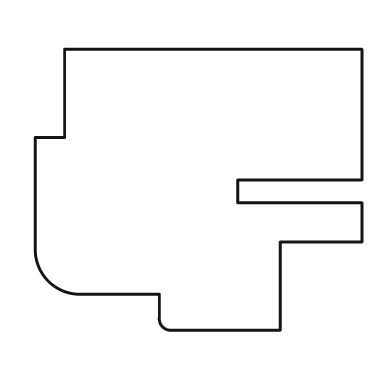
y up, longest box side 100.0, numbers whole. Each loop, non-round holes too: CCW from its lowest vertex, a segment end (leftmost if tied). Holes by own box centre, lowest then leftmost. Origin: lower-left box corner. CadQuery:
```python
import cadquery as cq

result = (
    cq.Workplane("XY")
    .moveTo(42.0, 0.0)
    .lineTo(75.0, 0.0)
    .lineTo(75.0, 27.0)
    .lineTo(100.0, 27.0)
    .lineTo(100.0, 39.0)
    .lineTo(62.0, 39.0)
    .lineTo(62.0, 46.0)
    .lineTo(100.0, 46.0)
    .lineTo(100.0, 86.0)
    .lineTo(9.0, 86.0)
    .lineTo(9.0, 59.0)
    .lineTo(0.0, 59.0)
    .lineTo(0.0, 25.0)
    .threePointArc((4.0, 15.0), (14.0, 11.0))
    .lineTo(38.0, 11.0)
    .lineTo(38.0, 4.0)
    .threePointArc((39.0, 1.0), (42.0, 0.0))
    .close()
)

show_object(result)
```